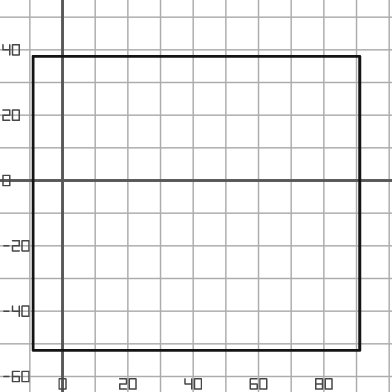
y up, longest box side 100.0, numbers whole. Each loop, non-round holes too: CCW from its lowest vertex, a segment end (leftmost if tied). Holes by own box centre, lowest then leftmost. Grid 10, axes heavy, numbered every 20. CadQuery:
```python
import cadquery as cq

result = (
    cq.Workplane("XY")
    .moveTo(-9.0, -52.0)
    .lineTo(91.0, -52.0)
    .lineTo(91.0, 38.0)
    .lineTo(-9.0, 38.0)
    .close()
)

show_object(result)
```